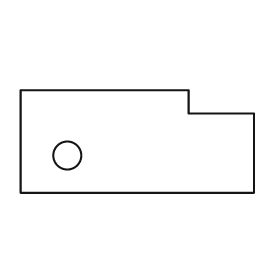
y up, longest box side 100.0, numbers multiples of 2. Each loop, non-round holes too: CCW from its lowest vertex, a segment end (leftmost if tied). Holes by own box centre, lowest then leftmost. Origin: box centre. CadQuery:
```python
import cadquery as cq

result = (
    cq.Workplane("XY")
    .moveTo(-50.0, -22.0)
    .lineTo(50.0, -22.0)
    .lineTo(50.0, 12.0)
    .lineTo(22.0, 12.0)
    .lineTo(22.0, 22.0)
    .lineTo(-50.0, 22.0)
    .close()
    .moveTo(-30.0, -6.0)
    .circle(6.0)
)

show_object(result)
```